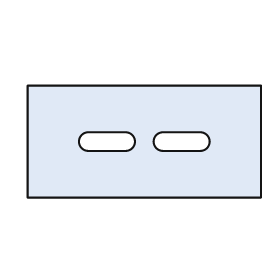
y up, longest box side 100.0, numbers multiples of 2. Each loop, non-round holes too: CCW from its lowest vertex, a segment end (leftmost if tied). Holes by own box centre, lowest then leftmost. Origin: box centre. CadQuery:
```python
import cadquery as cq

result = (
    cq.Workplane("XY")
    .moveTo(-50.0, -24.0)
    .lineTo(50.0, -24.0)
    .lineTo(50.0, 24.0)
    .lineTo(-50.0, 24.0)
    .close()
    .moveTo(-24.0, -4.0)
    .lineTo(-8.0, -4.0)
    .threePointArc((-4.0, 0.0), (-8.0, 4.0))
    .lineTo(-24.0, 4.0)
    .threePointArc((-28.0, 0.0), (-24.0, -4.0))
    .close()
    .moveTo(8.0, -4.0)
    .lineTo(24.0, -4.0)
    .threePointArc((28.0, 0.0), (24.0, 4.0))
    .lineTo(8.0, 4.0)
    .threePointArc((4.0, 0.0), (8.0, -4.0))
    .close()
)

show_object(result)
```